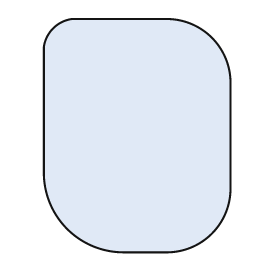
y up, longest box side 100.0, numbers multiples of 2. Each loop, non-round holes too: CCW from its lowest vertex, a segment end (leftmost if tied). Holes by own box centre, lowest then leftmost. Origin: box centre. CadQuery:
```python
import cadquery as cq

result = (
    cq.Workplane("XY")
    .moveTo(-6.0, -50.0)
    .lineTo(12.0, -50.0)
    .threePointArc((32.0, -42.0), (40.0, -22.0))
    .lineTo(40.0, 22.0)
    .threePointArc((32.0, 42.0), (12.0, 50.0))
    .lineTo(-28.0, 50.0)
    .threePointArc((-36.0, 46.0), (-40.0, 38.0))
    .lineTo(-40.0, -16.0)
    .threePointArc((-30.0, -40.0), (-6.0, -50.0))
    .close()
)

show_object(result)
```